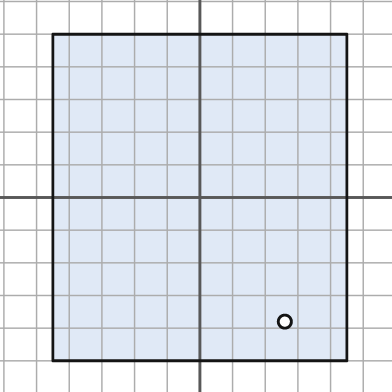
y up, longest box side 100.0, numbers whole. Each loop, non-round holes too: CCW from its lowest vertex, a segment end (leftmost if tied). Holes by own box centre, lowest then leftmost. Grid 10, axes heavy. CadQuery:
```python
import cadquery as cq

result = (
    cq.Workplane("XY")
    .moveTo(-45.0, -50.0)
    .lineTo(45.0, -50.0)
    .lineTo(45.0, 50.0)
    .lineTo(-45.0, 50.0)
    .close()
    .moveTo(26.0, -38.0)
    .circle(2.0)
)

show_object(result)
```